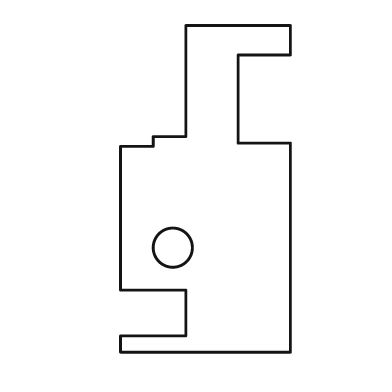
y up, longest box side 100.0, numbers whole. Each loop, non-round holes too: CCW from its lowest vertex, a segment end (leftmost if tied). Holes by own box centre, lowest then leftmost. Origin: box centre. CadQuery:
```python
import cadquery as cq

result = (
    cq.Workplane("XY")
    .moveTo(-26.0, -50.0)
    .lineTo(26.0, -50.0)
    .lineTo(26.0, 14.0)
    .lineTo(10.0, 14.0)
    .lineTo(10.0, 41.0)
    .lineTo(26.0, 41.0)
    .lineTo(26.0, 50.0)
    .lineTo(-6.0, 50.0)
    .lineTo(-6.0, 16.0)
    .lineTo(-16.0, 16.0)
    .lineTo(-16.0, 13.0)
    .lineTo(-26.0, 13.0)
    .lineTo(-26.0, -31.0)
    .lineTo(-6.0, -31.0)
    .lineTo(-6.0, -45.0)
    .lineTo(-26.0, -45.0)
    .close()
    .moveTo(-10.0, -18.0)
    .circle(6.0)
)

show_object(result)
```